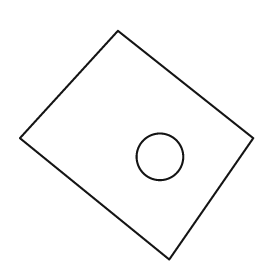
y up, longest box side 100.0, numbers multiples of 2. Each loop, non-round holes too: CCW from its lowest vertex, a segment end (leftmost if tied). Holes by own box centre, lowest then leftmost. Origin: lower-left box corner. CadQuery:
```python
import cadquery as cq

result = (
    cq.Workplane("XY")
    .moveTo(64.0, 0.0)
    .lineTo(100.0, 52.0)
    .lineTo(42.0, 98.0)
    .lineTo(0.0, 52.0)
    .close()
    .moveTo(60.0, 44.0)
    .circle(10.0)
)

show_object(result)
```